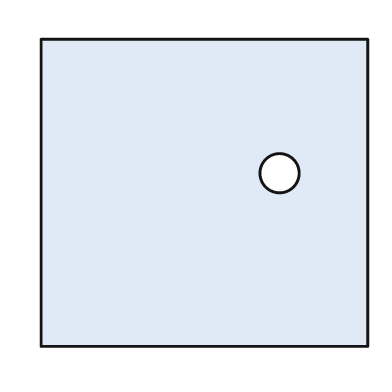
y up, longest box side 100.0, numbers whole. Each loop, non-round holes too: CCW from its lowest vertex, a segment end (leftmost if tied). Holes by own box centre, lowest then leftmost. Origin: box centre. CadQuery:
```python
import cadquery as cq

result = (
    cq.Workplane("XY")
    .moveTo(-50.0, -47.0)
    .lineTo(50.0, -47.0)
    .lineTo(50.0, 47.0)
    .lineTo(-50.0, 47.0)
    .close()
    .moveTo(23.0, 6.0)
    .circle(6.0)
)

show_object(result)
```